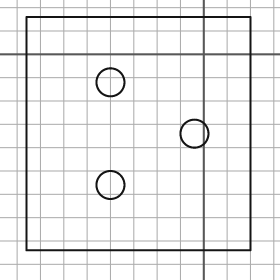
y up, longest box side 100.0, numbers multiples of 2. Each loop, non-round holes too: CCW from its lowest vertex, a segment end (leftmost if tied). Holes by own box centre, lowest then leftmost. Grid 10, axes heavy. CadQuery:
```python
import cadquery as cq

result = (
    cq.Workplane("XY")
    .moveTo(-76.0, -84.0)
    .lineTo(20.0, -84.0)
    .lineTo(20.0, 16.0)
    .lineTo(-76.0, 16.0)
    .close()
    .moveTo(-40.0, -56.0)
    .circle(6.0)
    .moveTo(-4.0, -34.0)
    .circle(6.0)
    .moveTo(-40.0, -12.0)
    .circle(6.0)
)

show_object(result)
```